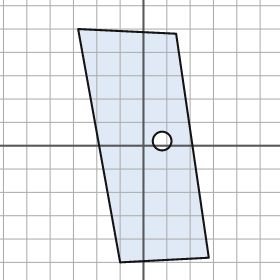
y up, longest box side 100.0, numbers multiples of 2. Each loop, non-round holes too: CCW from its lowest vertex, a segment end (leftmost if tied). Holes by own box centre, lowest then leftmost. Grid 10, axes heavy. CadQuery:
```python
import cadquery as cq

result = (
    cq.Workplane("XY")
    .moveTo(-10.0, -50.0)
    .lineTo(28.0, -48.0)
    .lineTo(14.0, 48.0)
    .lineTo(-28.0, 50.0)
    .close()
    .moveTo(8.0, 2.0)
    .circle(4.0)
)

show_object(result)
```